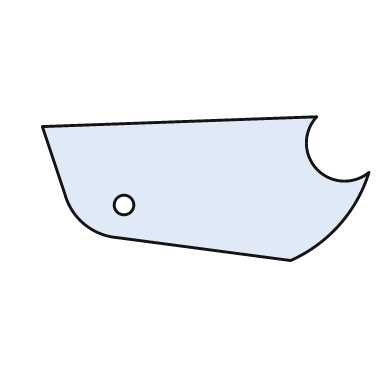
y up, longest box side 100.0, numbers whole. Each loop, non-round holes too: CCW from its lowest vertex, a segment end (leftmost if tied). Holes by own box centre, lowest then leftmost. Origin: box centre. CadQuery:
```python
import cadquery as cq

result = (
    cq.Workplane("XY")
    .moveTo(26.0, -22.0)
    .threePointArc((41.0, -11.0), (50.0, 5.0))
    .threePointArc((34.0, 6.0), (34.0, 22.0))
    .lineTo(-50.0, 19.0)
    .lineTo(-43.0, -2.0)
    .threePointArc((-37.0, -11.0), (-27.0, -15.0))
    .close()
    .moveTo(-25.0, -5.0)
    .circle(3.0)
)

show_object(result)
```